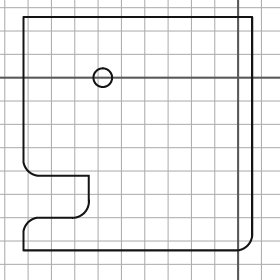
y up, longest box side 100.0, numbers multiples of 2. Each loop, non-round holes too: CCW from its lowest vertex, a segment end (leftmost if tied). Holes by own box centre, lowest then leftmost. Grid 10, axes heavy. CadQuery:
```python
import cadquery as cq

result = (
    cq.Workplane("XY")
    .moveTo(-92.0, -74.0)
    .lineTo(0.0, -74.0)
    .threePointArc((4.0, -72.0), (6.0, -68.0))
    .lineTo(6.0, 26.0)
    .lineTo(-92.0, 26.0)
    .lineTo(-92.0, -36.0)
    .threePointArc((-90.0, -40.0), (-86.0, -42.0))
    .lineTo(-64.0, -42.0)
    .lineTo(-64.0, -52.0)
    .threePointArc((-66.0, -58.0), (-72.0, -60.0))
    .lineTo(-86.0, -60.0)
    .threePointArc((-90.0, -62.0), (-92.0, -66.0))
    .close()
    .moveTo(-58.0, 0.0)
    .circle(4.0)
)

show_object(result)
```